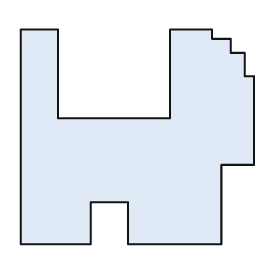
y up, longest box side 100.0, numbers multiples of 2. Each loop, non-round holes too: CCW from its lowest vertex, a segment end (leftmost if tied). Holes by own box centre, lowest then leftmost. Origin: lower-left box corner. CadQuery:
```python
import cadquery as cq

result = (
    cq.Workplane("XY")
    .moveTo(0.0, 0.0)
    .lineTo(30.0, 0.0)
    .lineTo(30.0, 18.0)
    .lineTo(46.0, 18.0)
    .lineTo(46.0, 0.0)
    .lineTo(86.0, 0.0)
    .lineTo(86.0, 34.0)
    .lineTo(100.0, 34.0)
    .lineTo(100.0, 72.0)
    .lineTo(96.0, 72.0)
    .lineTo(96.0, 82.0)
    .lineTo(90.0, 82.0)
    .lineTo(90.0, 88.0)
    .lineTo(82.0, 88.0)
    .lineTo(82.0, 92.0)
    .lineTo(64.0, 92.0)
    .lineTo(64.0, 54.0)
    .lineTo(16.0, 54.0)
    .lineTo(16.0, 92.0)
    .lineTo(0.0, 92.0)
    .close()
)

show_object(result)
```